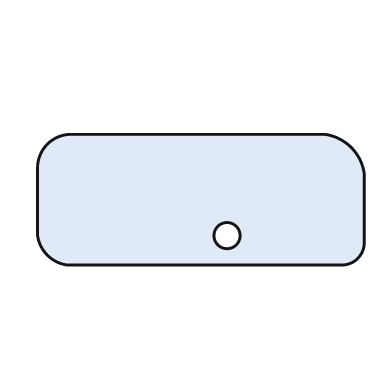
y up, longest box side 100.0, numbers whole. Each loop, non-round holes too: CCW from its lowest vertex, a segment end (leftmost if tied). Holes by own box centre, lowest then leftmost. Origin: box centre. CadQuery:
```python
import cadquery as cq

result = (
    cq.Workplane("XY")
    .moveTo(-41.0, -20.0)
    .lineTo(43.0, -20.0)
    .threePointArc((48.0, -18.0), (50.0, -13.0))
    .lineTo(50.0, 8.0)
    .threePointArc((46.0, 16.0), (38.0, 20.0))
    .lineTo(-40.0, 20.0)
    .threePointArc((-47.0, 17.0), (-50.0, 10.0))
    .lineTo(-50.0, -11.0)
    .threePointArc((-47.0, -17.0), (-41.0, -20.0))
    .close()
    .moveTo(8.0, -11.0)
    .circle(4.0)
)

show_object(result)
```